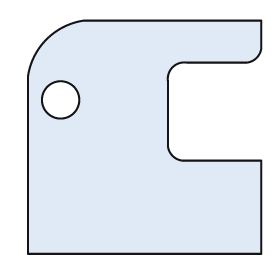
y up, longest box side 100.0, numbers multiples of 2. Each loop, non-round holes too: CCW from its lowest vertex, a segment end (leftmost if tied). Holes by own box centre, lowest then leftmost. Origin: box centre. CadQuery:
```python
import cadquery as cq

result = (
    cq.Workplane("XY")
    .moveTo(-50.0, -50.0)
    .lineTo(50.0, -50.0)
    .lineTo(50.0, -10.0)
    .lineTo(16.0, -10.0)
    .threePointArc((12.0, -8.0), (10.0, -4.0))
    .lineTo(10.0, 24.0)
    .threePointArc((12.0, 30.0), (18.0, 32.0))
    .lineTo(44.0, 32.0)
    .threePointArc((48.0, 34.0), (50.0, 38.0))
    .lineTo(50.0, 50.0)
    .lineTo(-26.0, 50.0)
    .threePointArc((-42.0, 42.0), (-50.0, 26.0))
    .close()
    .moveTo(-36.0, 16.0)
    .circle(8.0)
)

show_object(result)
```